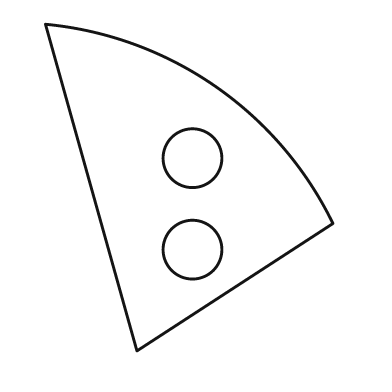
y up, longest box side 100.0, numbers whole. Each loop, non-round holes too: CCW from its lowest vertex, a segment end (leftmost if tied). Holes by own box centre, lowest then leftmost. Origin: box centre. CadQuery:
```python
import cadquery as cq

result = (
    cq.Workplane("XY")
    .moveTo(-16.0, -50.0)
    .lineTo(44.0, -11.0)
    .threePointArc((8.0, 31.0), (-44.0, 50.0))
    .close()
    .moveTo(1.0, -19.0)
    .circle(9.0)
    .moveTo(1.0, 9.0)
    .circle(9.0)
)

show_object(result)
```